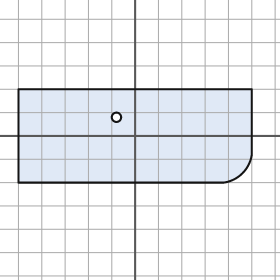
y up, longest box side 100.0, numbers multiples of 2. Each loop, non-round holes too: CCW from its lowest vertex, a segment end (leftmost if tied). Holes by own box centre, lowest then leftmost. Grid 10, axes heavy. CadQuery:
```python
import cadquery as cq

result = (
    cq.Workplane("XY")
    .moveTo(-50.0, -20.0)
    .lineTo(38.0, -20.0)
    .threePointArc((46.0, -16.0), (50.0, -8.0))
    .lineTo(50.0, 20.0)
    .lineTo(-50.0, 20.0)
    .close()
    .moveTo(-8.0, 8.0)
    .circle(2.0)
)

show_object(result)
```